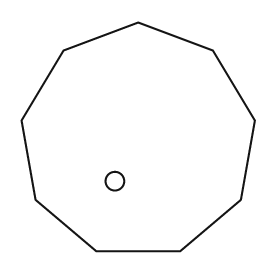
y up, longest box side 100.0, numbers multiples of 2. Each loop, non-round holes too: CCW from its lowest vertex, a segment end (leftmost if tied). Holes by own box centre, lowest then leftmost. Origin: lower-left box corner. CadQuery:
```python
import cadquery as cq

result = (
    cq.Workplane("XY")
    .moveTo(32.0, 0.0)
    .lineTo(68.0, 0.0)
    .lineTo(94.0, 22.0)
    .lineTo(100.0, 56.0)
    .lineTo(82.0, 86.0)
    .lineTo(50.0, 98.0)
    .lineTo(18.0, 86.0)
    .lineTo(0.0, 56.0)
    .lineTo(6.0, 22.0)
    .close()
    .moveTo(40.0, 30.0)
    .circle(4.0)
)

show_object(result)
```